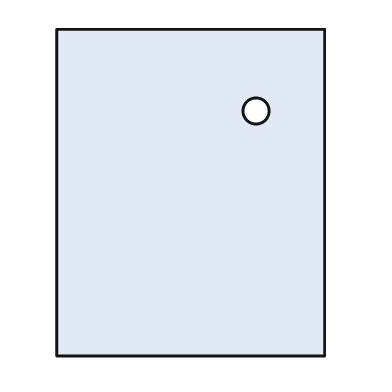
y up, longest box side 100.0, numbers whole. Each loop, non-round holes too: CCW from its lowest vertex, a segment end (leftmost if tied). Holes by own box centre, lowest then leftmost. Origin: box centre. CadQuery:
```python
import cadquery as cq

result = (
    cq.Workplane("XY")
    .moveTo(-41.0, -50.0)
    .lineTo(41.0, -50.0)
    .lineTo(41.0, 50.0)
    .lineTo(-41.0, 50.0)
    .close()
    .moveTo(20.0, 25.0)
    .circle(4.0)
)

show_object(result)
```